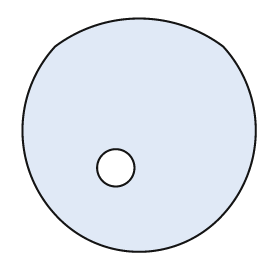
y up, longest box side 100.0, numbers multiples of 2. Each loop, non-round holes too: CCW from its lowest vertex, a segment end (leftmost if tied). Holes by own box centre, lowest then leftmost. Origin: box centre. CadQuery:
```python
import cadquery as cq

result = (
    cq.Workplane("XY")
    .moveTo(-36.0, -34.0)
    .threePointArc((0.0, -50.0), (36.0, -34.0))
    .threePointArc((50.0, 2.0), (36.0, 38.0))
    .threePointArc((0.0, 50.0), (-36.0, 38.0))
    .threePointArc((-50.0, 2.0), (-36.0, -34.0))
    .close()
    .moveTo(-10.0, -14.0)
    .circle(8.0)
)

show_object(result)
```